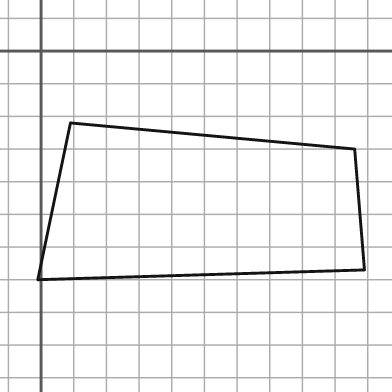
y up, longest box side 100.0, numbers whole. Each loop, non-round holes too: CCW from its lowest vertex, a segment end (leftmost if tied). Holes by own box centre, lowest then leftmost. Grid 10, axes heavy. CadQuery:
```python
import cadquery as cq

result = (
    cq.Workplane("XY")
    .moveTo(-1.0, -70.0)
    .lineTo(99.0, -67.0)
    .lineTo(96.0, -30.0)
    .lineTo(9.0, -22.0)
    .close()
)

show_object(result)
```